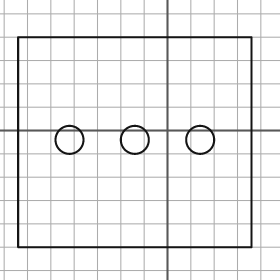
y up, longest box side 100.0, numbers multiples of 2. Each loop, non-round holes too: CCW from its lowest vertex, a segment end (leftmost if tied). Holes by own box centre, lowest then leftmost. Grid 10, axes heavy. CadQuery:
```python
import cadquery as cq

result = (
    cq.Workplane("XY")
    .moveTo(-64.0, -50.0)
    .lineTo(36.0, -50.0)
    .lineTo(36.0, 40.0)
    .lineTo(-64.0, 40.0)
    .close()
    .moveTo(-42.0, -4.0)
    .circle(6.0)
    .moveTo(-14.0, -4.0)
    .circle(6.0)
    .moveTo(14.0, -4.0)
    .circle(6.0)
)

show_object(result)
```